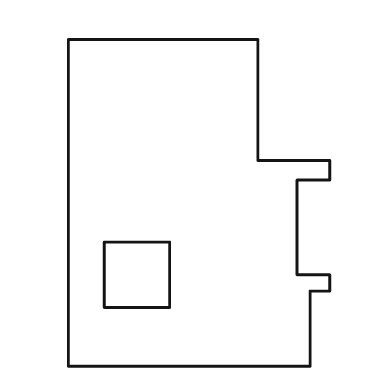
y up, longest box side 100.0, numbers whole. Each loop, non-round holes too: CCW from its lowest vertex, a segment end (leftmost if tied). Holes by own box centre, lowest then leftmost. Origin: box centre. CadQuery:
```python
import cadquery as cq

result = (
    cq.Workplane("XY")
    .moveTo(-40.0, -50.0)
    .lineTo(34.0, -50.0)
    .lineTo(34.0, -27.0)
    .lineTo(40.0, -27.0)
    .lineTo(40.0, -22.0)
    .lineTo(30.0, -22.0)
    .lineTo(30.0, 7.0)
    .lineTo(40.0, 7.0)
    .lineTo(40.0, 13.0)
    .lineTo(18.0, 13.0)
    .lineTo(18.0, 50.0)
    .lineTo(-40.0, 50.0)
    .close()
    .moveTo(-29.0, -32.0)
    .lineTo(-9.0, -32.0)
    .lineTo(-9.0, -12.0)
    .lineTo(-29.0, -12.0)
    .close()
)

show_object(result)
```